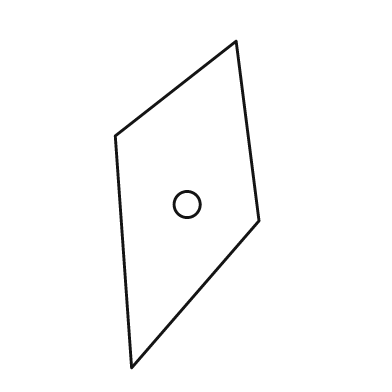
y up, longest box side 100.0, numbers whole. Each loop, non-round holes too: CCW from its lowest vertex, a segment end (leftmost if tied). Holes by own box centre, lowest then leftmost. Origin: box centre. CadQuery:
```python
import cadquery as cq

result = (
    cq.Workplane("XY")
    .moveTo(-17.0, -50.0)
    .lineTo(22.0, -5.0)
    .lineTo(15.0, 50.0)
    .lineTo(-22.0, 21.0)
    .close()
    .moveTo(0.0, 0.0)
    .circle(4.0)
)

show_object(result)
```